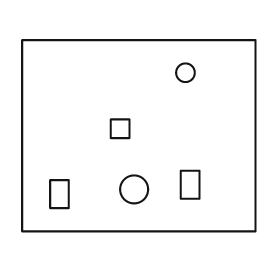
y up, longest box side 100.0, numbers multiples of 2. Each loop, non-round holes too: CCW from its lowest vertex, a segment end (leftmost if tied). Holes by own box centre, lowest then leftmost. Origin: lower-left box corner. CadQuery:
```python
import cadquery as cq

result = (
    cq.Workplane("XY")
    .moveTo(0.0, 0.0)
    .lineTo(100.0, 0.0)
    .lineTo(100.0, 82.0)
    .lineTo(0.0, 82.0)
    .close()
    .moveTo(12.0, 10.0)
    .lineTo(20.0, 10.0)
    .lineTo(20.0, 22.0)
    .lineTo(12.0, 22.0)
    .close()
    .moveTo(48.0, 18.0)
    .circle(6.0)
    .moveTo(68.0, 14.0)
    .lineTo(76.0, 14.0)
    .lineTo(76.0, 26.0)
    .lineTo(68.0, 26.0)
    .close()
    .moveTo(38.0, 40.0)
    .lineTo(46.0, 40.0)
    .lineTo(46.0, 48.0)
    .lineTo(38.0, 48.0)
    .close()
    .moveTo(70.0, 68.0)
    .circle(4.0)
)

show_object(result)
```